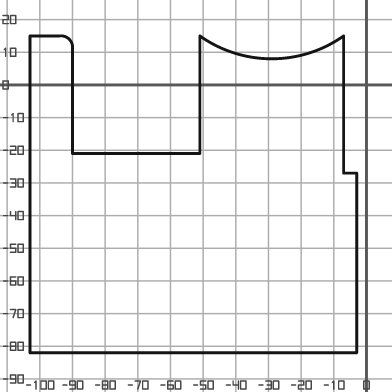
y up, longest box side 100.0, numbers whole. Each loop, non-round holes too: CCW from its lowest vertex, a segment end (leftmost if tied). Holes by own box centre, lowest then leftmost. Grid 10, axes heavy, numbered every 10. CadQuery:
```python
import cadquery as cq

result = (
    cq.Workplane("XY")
    .moveTo(-103.0, -82.0)
    .lineTo(-3.0, -82.0)
    .lineTo(-3.0, -27.0)
    .lineTo(-7.0, -27.0)
    .lineTo(-7.0, 15.0)
    .threePointArc((-29.0, 8.0), (-51.0, 15.0))
    .lineTo(-51.0, -21.0)
    .lineTo(-90.0, -21.0)
    .lineTo(-90.0, 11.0)
    .threePointArc((-91.0, 14.0), (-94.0, 15.0))
    .lineTo(-103.0, 15.0)
    .close()
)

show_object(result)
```